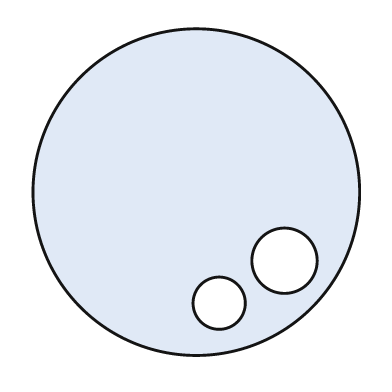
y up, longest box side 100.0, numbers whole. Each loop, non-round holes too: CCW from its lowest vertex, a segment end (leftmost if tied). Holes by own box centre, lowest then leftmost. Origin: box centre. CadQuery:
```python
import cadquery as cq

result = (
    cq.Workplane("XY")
    .moveTo(0.0, 0.0)
    .circle(50.0)
    .moveTo(7.0, -34.0)
    .circle(8.0)
    .moveTo(27.0, -21.0)
    .circle(10.0)
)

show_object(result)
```